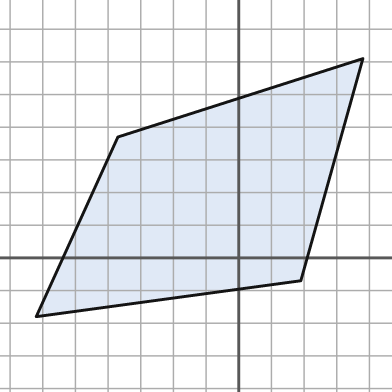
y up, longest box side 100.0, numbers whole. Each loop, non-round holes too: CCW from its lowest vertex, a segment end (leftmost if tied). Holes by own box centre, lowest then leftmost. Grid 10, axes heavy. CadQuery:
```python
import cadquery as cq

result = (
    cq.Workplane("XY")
    .moveTo(-62.0, -18.0)
    .lineTo(19.0, -7.0)
    .lineTo(38.0, 61.0)
    .lineTo(-37.0, 37.0)
    .close()
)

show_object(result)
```